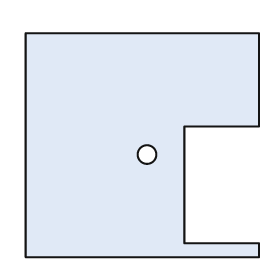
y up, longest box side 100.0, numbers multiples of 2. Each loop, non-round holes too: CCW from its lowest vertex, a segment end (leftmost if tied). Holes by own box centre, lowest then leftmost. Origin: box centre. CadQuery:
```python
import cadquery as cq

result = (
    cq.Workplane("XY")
    .moveTo(-50.0, -48.0)
    .lineTo(50.0, -48.0)
    .lineTo(50.0, -42.0)
    .lineTo(18.0, -42.0)
    .lineTo(18.0, 8.0)
    .lineTo(50.0, 8.0)
    .lineTo(50.0, 48.0)
    .lineTo(-50.0, 48.0)
    .close()
    .moveTo(2.0, -4.0)
    .circle(4.0)
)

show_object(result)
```